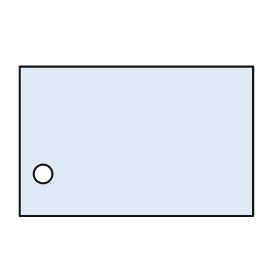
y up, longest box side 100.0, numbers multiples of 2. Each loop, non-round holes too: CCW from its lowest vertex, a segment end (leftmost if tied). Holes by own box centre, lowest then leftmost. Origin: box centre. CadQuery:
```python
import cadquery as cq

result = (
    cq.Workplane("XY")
    .moveTo(-50.0, -32.0)
    .lineTo(50.0, -32.0)
    .lineTo(50.0, 32.0)
    .lineTo(-50.0, 32.0)
    .close()
    .moveTo(-40.0, -14.0)
    .circle(4.0)
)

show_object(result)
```